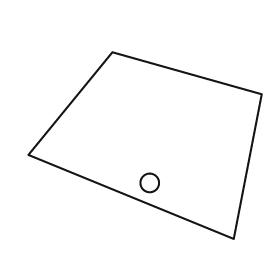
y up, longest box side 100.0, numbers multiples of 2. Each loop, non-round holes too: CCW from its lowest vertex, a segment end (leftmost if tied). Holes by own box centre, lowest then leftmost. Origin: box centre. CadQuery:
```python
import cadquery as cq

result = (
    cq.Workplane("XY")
    .moveTo(38.0, -40.0)
    .lineTo(50.0, 22.0)
    .lineTo(-14.0, 40.0)
    .lineTo(-50.0, -4.0)
    .close()
    .moveTo(2.0, -16.0)
    .circle(4.0)
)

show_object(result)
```